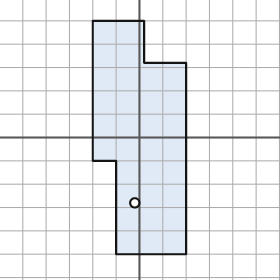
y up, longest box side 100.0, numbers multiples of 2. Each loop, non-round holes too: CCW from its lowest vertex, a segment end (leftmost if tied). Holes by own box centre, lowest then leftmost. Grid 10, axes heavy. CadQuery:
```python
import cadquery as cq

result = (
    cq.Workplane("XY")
    .moveTo(-10.0, -50.0)
    .lineTo(20.0, -50.0)
    .lineTo(20.0, 32.0)
    .lineTo(2.0, 32.0)
    .lineTo(2.0, 50.0)
    .lineTo(-20.0, 50.0)
    .lineTo(-20.0, -10.0)
    .lineTo(-10.0, -10.0)
    .close()
    .moveTo(-2.0, -28.0)
    .circle(2.0)
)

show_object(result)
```